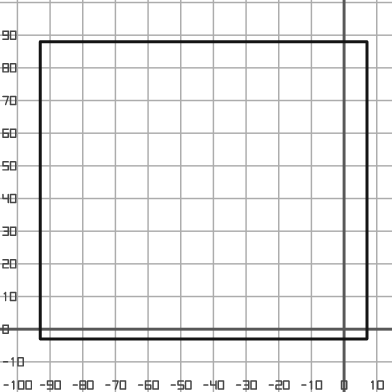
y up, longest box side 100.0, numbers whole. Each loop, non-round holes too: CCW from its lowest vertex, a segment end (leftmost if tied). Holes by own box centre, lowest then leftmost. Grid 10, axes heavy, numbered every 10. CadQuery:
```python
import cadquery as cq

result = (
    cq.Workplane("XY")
    .moveTo(-93.0, -3.0)
    .lineTo(7.0, -3.0)
    .lineTo(7.0, 88.0)
    .lineTo(-93.0, 88.0)
    .close()
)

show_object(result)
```